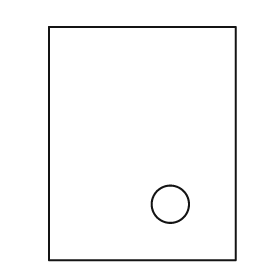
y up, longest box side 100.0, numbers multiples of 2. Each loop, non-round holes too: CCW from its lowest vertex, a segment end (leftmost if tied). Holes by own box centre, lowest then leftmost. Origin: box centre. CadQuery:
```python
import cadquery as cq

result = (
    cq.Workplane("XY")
    .moveTo(-40.0, -50.0)
    .lineTo(40.0, -50.0)
    .lineTo(40.0, 50.0)
    .lineTo(-40.0, 50.0)
    .close()
    .moveTo(12.0, -26.0)
    .circle(8.0)
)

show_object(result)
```